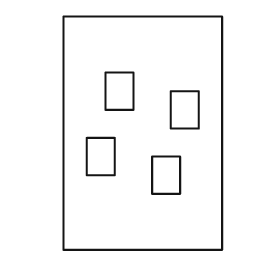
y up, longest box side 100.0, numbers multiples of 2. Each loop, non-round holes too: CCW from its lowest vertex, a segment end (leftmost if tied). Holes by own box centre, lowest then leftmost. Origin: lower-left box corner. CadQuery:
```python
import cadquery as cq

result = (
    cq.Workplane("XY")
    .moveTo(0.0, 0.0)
    .lineTo(68.0, 0.0)
    .lineTo(68.0, 100.0)
    .lineTo(0.0, 100.0)
    .close()
    .moveTo(38.0, 24.0)
    .lineTo(50.0, 24.0)
    .lineTo(50.0, 40.0)
    .lineTo(38.0, 40.0)
    .close()
    .moveTo(10.0, 32.0)
    .lineTo(22.0, 32.0)
    .lineTo(22.0, 48.0)
    .lineTo(10.0, 48.0)
    .close()
    .moveTo(46.0, 52.0)
    .lineTo(58.0, 52.0)
    .lineTo(58.0, 68.0)
    .lineTo(46.0, 68.0)
    .close()
    .moveTo(18.0, 60.0)
    .lineTo(30.0, 60.0)
    .lineTo(30.0, 76.0)
    .lineTo(18.0, 76.0)
    .close()
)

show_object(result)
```